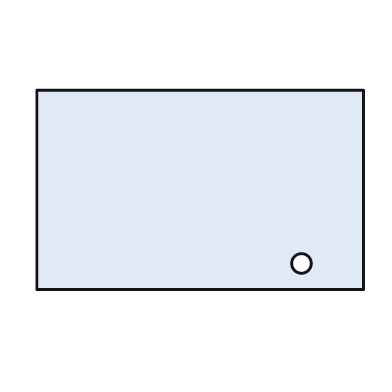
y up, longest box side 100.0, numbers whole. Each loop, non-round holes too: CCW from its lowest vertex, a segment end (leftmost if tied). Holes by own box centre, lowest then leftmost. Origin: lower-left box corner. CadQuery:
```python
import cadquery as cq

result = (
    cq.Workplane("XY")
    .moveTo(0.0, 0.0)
    .lineTo(100.0, 0.0)
    .lineTo(100.0, 61.0)
    .lineTo(0.0, 61.0)
    .close()
    .moveTo(81.0, 8.0)
    .circle(3.0)
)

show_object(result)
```